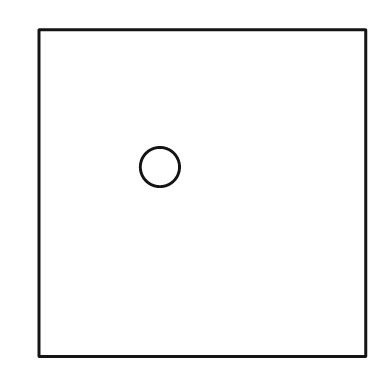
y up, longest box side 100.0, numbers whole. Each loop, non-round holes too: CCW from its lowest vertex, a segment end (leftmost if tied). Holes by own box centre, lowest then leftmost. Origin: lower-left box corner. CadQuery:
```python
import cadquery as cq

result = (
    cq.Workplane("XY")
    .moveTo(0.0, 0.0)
    .lineTo(100.0, 0.0)
    .lineTo(100.0, 100.0)
    .lineTo(0.0, 100.0)
    .close()
    .moveTo(37.0, 58.0)
    .circle(6.0)
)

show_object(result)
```